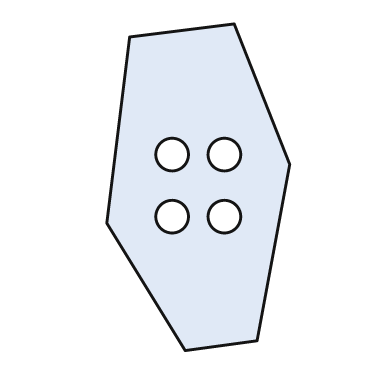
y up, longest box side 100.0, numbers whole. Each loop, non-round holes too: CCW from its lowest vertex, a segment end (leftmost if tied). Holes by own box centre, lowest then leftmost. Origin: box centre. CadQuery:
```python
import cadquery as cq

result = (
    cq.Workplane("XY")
    .moveTo(-4.0, -50.0)
    .lineTo(18.0, -47.0)
    .lineTo(28.0, 7.0)
    .lineTo(11.0, 50.0)
    .lineTo(-21.0, 46.0)
    .lineTo(-28.0, -11.0)
    .close()
    .moveTo(-8.0, -9.0)
    .circle(5.0)
    .moveTo(8.0, -9.0)
    .circle(5.0)
    .moveTo(-8.0, 10.0)
    .circle(5.0)
    .moveTo(8.0, 10.0)
    .circle(5.0)
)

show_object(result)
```